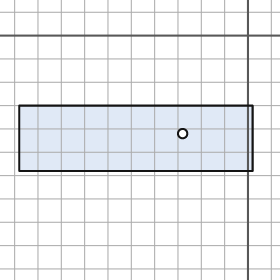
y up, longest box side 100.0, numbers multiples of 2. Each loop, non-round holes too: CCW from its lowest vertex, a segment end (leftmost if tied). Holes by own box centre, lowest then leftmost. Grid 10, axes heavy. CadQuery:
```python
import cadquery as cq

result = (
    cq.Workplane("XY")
    .moveTo(-98.0, -58.0)
    .lineTo(2.0, -58.0)
    .lineTo(2.0, -30.0)
    .lineTo(-98.0, -30.0)
    .close()
    .moveTo(-28.0, -42.0)
    .circle(2.0)
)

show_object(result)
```